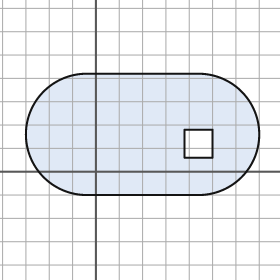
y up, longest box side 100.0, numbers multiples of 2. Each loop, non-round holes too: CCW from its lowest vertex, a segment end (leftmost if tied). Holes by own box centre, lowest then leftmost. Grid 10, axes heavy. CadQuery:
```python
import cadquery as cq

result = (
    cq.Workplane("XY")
    .moveTo(-4.0, -10.0)
    .lineTo(44.0, -10.0)
    .threePointArc((70.0, 16.0), (44.0, 42.0))
    .lineTo(-4.0, 42.0)
    .threePointArc((-30.0, 16.0), (-4.0, -10.0))
    .close()
    .moveTo(38.0, 6.0)
    .lineTo(50.0, 6.0)
    .lineTo(50.0, 18.0)
    .lineTo(38.0, 18.0)
    .close()
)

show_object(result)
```